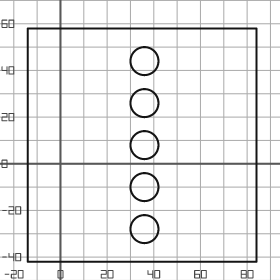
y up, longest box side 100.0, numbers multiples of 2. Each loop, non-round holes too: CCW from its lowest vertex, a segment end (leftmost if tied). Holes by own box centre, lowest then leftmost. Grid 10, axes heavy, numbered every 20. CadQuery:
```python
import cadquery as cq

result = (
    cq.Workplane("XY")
    .moveTo(-14.0, -42.0)
    .lineTo(84.0, -42.0)
    .lineTo(84.0, 58.0)
    .lineTo(-14.0, 58.0)
    .close()
    .moveTo(36.0, -28.0)
    .circle(6.0)
    .moveTo(36.0, -10.0)
    .circle(6.0)
    .moveTo(36.0, 8.0)
    .circle(6.0)
    .moveTo(36.0, 26.0)
    .circle(6.0)
    .moveTo(36.0, 44.0)
    .circle(6.0)
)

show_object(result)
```